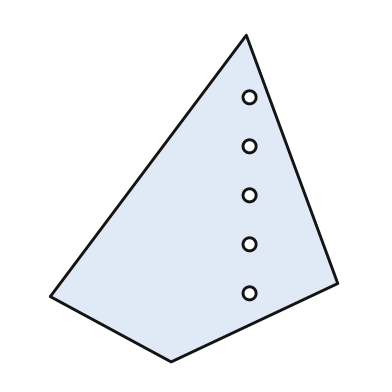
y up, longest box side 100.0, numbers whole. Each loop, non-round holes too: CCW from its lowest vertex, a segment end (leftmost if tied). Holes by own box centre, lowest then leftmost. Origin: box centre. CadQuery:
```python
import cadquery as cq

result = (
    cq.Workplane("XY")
    .moveTo(-7.0, -50.0)
    .lineTo(44.0, -26.0)
    .lineTo(16.0, 50.0)
    .lineTo(-44.0, -30.0)
    .close()
    .moveTo(17.0, -29.0)
    .circle(2.0)
    .moveTo(17.0, -14.0)
    .circle(2.0)
    .moveTo(17.0, 1.0)
    .circle(2.0)
    .moveTo(17.0, 16.0)
    .circle(2.0)
    .moveTo(17.0, 31.0)
    .circle(2.0)
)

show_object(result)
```